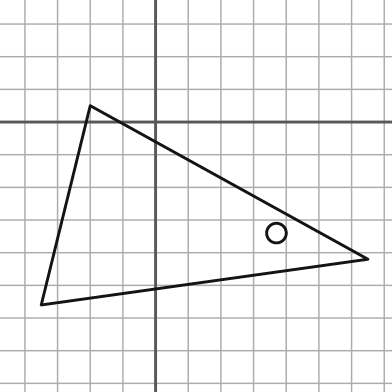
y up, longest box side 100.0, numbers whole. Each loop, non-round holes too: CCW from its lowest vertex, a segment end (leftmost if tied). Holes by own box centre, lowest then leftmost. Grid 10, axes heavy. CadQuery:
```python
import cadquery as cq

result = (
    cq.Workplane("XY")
    .moveTo(-35.0, -56.0)
    .lineTo(65.0, -42.0)
    .lineTo(-20.0, 5.0)
    .close()
    .moveTo(37.0, -34.0)
    .circle(3.0)
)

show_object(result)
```